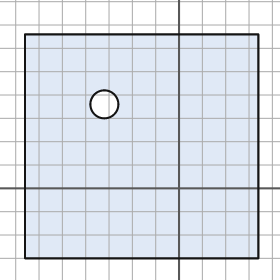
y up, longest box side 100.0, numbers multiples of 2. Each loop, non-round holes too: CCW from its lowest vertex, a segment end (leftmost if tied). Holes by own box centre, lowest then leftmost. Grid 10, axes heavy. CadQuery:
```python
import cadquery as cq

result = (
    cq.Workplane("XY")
    .moveTo(-66.0, -30.0)
    .lineTo(34.0, -30.0)
    .lineTo(34.0, 66.0)
    .lineTo(-66.0, 66.0)
    .close()
    .moveTo(-32.0, 36.0)
    .circle(6.0)
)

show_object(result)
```